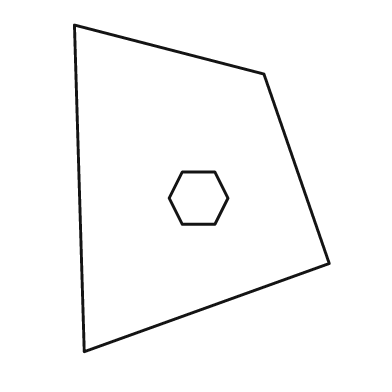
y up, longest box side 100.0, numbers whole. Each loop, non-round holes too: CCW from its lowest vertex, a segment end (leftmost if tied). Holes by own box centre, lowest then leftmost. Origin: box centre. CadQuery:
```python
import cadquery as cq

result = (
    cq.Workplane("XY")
    .moveTo(-36.0, -50.0)
    .lineTo(39.0, -23.0)
    .lineTo(19.0, 35.0)
    .lineTo(-39.0, 50.0)
    .close()
    .moveTo(-6.0, -11.0)
    .lineTo(4.0, -11.0)
    .lineTo(8.0, -3.0)
    .lineTo(4.0, 5.0)
    .lineTo(-6.0, 5.0)
    .lineTo(-10.0, -3.0)
    .close()
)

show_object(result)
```